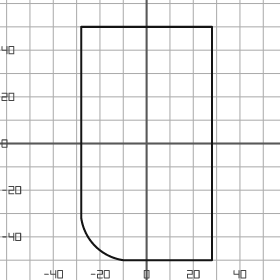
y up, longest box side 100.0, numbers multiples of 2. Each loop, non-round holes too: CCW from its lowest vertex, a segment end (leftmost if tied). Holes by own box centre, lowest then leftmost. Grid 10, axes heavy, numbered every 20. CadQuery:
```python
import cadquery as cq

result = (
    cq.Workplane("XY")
    .moveTo(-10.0, -50.0)
    .lineTo(28.0, -50.0)
    .lineTo(28.0, 50.0)
    .lineTo(-28.0, 50.0)
    .lineTo(-28.0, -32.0)
    .threePointArc((-22.0, -44.0), (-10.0, -50.0))
    .close()
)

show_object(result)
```